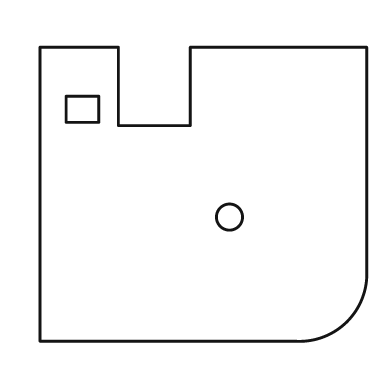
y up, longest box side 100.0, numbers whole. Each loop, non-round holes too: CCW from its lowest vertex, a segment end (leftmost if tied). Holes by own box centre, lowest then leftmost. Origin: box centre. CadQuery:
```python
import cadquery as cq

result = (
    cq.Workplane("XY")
    .moveTo(-50.0, -45.0)
    .lineTo(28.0, -45.0)
    .threePointArc((44.0, -39.0), (50.0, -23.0))
    .lineTo(50.0, 45.0)
    .lineTo(-4.0, 45.0)
    .lineTo(-4.0, 21.0)
    .lineTo(-26.0, 21.0)
    .lineTo(-26.0, 45.0)
    .lineTo(-50.0, 45.0)
    .close()
    .moveTo(8.0, -7.0)
    .circle(4.0)
    .moveTo(-42.0, 22.0)
    .lineTo(-32.0, 22.0)
    .lineTo(-32.0, 30.0)
    .lineTo(-42.0, 30.0)
    .close()
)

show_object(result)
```